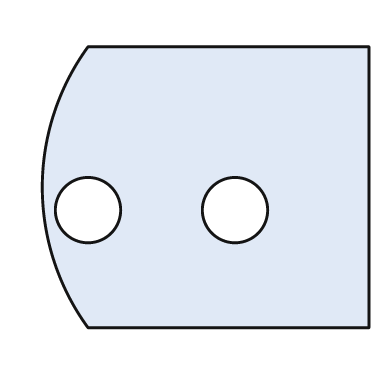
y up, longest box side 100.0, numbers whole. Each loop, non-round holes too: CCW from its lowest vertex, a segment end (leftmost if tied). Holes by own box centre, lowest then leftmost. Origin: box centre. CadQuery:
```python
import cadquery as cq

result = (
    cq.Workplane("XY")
    .moveTo(-36.0, -43.0)
    .lineTo(50.0, -43.0)
    .lineTo(50.0, 43.0)
    .lineTo(-36.0, 43.0)
    .threePointArc((-50.0, 0.0), (-36.0, -43.0))
    .close()
    .moveTo(-36.0, -7.0)
    .circle(10.0)
    .moveTo(9.0, -7.0)
    .circle(10.0)
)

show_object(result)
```